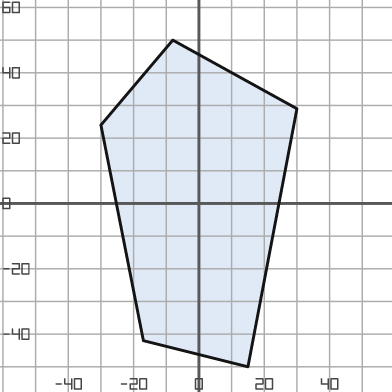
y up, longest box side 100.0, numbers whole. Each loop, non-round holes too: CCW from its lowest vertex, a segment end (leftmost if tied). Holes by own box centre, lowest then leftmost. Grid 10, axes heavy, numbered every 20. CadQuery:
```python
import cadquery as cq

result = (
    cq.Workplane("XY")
    .moveTo(15.0, -50.0)
    .lineTo(30.0, 29.0)
    .lineTo(-8.0, 50.0)
    .lineTo(-30.0, 24.0)
    .lineTo(-17.0, -42.0)
    .close()
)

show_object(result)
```